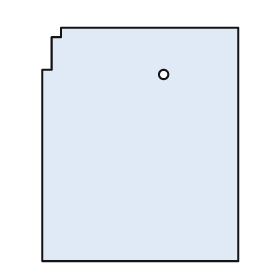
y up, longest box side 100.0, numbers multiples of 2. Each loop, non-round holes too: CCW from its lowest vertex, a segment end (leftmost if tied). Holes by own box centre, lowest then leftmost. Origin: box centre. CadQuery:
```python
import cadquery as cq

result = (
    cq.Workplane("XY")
    .moveTo(-42.0, -50.0)
    .lineTo(42.0, -50.0)
    .lineTo(42.0, 50.0)
    .lineTo(-34.0, 50.0)
    .lineTo(-34.0, 46.0)
    .lineTo(-38.0, 46.0)
    .lineTo(-38.0, 32.0)
    .lineTo(-42.0, 32.0)
    .close()
    .moveTo(10.0, 30.0)
    .circle(2.0)
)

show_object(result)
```